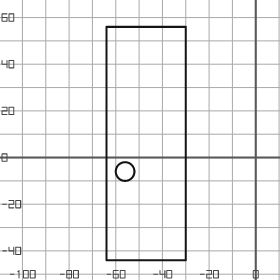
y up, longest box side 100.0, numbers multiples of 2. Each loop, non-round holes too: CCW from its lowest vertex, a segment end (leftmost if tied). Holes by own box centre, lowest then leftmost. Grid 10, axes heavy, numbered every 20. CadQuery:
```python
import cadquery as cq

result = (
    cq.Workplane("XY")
    .moveTo(-64.0, -44.0)
    .lineTo(-30.0, -44.0)
    .lineTo(-30.0, 56.0)
    .lineTo(-64.0, 56.0)
    .close()
    .moveTo(-56.0, -6.0)
    .circle(4.0)
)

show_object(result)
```